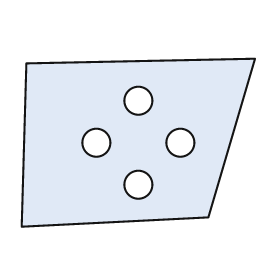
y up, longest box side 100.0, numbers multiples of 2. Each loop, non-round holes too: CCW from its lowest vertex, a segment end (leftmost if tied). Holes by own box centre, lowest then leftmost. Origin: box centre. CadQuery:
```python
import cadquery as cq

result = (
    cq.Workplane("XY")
    .moveTo(-50.0, -36.0)
    .lineTo(30.0, -32.0)
    .lineTo(50.0, 36.0)
    .lineTo(-48.0, 34.0)
    .close()
    .moveTo(0.0, -18.0)
    .circle(6.0)
    .moveTo(-18.0, 0.0)
    .circle(6.0)
    .moveTo(18.0, 0.0)
    .circle(6.0)
    .moveTo(0.0, 18.0)
    .circle(6.0)
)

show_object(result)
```